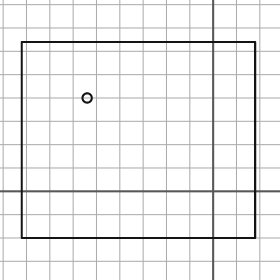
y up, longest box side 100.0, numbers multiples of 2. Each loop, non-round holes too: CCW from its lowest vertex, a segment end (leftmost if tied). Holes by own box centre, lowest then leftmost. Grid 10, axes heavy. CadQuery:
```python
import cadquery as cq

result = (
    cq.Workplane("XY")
    .moveTo(-82.0, -20.0)
    .lineTo(18.0, -20.0)
    .lineTo(18.0, 64.0)
    .lineTo(-82.0, 64.0)
    .close()
    .moveTo(-54.0, 40.0)
    .circle(2.0)
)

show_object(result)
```